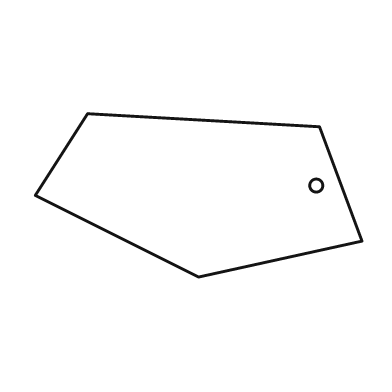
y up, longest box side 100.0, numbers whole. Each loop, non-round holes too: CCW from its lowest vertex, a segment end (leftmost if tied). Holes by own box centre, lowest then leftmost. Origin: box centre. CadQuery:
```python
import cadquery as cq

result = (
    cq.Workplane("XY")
    .moveTo(0.0, -25.0)
    .lineTo(50.0, -14.0)
    .lineTo(37.0, 21.0)
    .lineTo(-34.0, 25.0)
    .lineTo(-50.0, 0.0)
    .close()
    .moveTo(36.0, 3.0)
    .circle(2.0)
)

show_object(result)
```